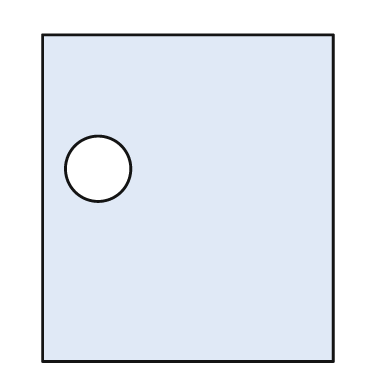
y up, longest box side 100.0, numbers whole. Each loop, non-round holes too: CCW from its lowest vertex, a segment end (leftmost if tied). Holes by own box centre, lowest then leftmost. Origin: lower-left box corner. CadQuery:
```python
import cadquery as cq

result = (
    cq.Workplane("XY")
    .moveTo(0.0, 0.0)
    .lineTo(89.0, 0.0)
    .lineTo(89.0, 100.0)
    .lineTo(0.0, 100.0)
    .close()
    .moveTo(17.0, 59.0)
    .circle(10.0)
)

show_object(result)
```